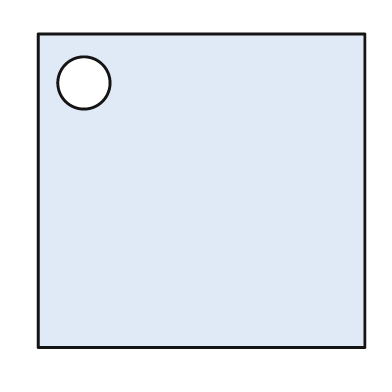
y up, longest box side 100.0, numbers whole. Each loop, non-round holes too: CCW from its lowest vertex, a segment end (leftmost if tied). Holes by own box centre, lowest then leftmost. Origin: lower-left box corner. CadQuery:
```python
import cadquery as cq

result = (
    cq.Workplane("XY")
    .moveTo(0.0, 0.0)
    .lineTo(100.0, 0.0)
    .lineTo(100.0, 96.0)
    .lineTo(0.0, 96.0)
    .close()
    .moveTo(14.0, 81.0)
    .circle(8.0)
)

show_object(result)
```